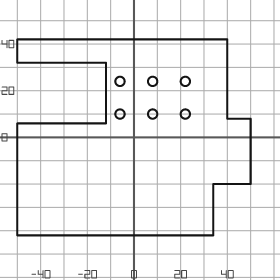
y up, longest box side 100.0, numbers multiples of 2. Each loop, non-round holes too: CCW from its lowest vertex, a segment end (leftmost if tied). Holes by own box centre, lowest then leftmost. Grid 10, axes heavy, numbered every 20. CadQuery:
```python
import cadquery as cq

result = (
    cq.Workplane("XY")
    .moveTo(-50.0, -42.0)
    .lineTo(34.0, -42.0)
    .lineTo(34.0, -20.0)
    .lineTo(50.0, -20.0)
    .lineTo(50.0, 8.0)
    .lineTo(40.0, 8.0)
    .lineTo(40.0, 42.0)
    .lineTo(-50.0, 42.0)
    .lineTo(-50.0, 32.0)
    .lineTo(-12.0, 32.0)
    .lineTo(-12.0, 6.0)
    .lineTo(-50.0, 6.0)
    .close()
    .moveTo(-6.0, 10.0)
    .circle(2.0)
    .moveTo(8.0, 10.0)
    .circle(2.0)
    .moveTo(22.0, 10.0)
    .circle(2.0)
    .moveTo(-6.0, 24.0)
    .circle(2.0)
    .moveTo(8.0, 24.0)
    .circle(2.0)
    .moveTo(22.0, 24.0)
    .circle(2.0)
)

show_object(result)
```